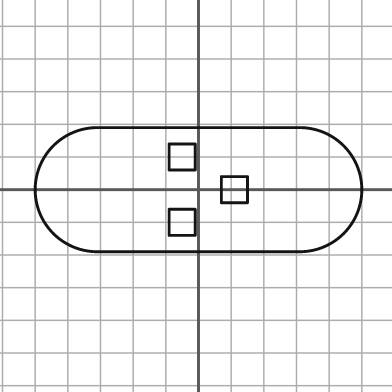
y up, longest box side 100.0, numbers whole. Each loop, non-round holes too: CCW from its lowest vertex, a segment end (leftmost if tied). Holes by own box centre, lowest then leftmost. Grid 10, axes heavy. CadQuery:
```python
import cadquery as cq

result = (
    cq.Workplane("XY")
    .moveTo(-31.0, -19.0)
    .lineTo(31.0, -19.0)
    .threePointArc((50.0, 0.0), (31.0, 19.0))
    .lineTo(-31.0, 19.0)
    .threePointArc((-50.0, 0.0), (-31.0, -19.0))
    .close()
    .moveTo(-9.0, -14.0)
    .lineTo(-1.0, -14.0)
    .lineTo(-1.0, -6.0)
    .lineTo(-9.0, -6.0)
    .close()
    .moveTo(7.0, -4.0)
    .lineTo(15.0, -4.0)
    .lineTo(15.0, 4.0)
    .lineTo(7.0, 4.0)
    .close()
    .moveTo(-9.0, 6.0)
    .lineTo(-1.0, 6.0)
    .lineTo(-1.0, 14.0)
    .lineTo(-9.0, 14.0)
    .close()
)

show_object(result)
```